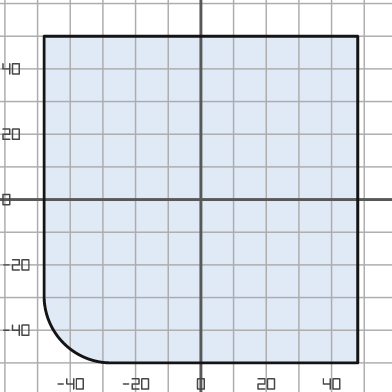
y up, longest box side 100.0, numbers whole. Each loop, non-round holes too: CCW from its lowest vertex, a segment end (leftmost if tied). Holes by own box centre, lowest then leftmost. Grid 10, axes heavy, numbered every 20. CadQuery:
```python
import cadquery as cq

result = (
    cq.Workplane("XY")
    .moveTo(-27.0, -50.0)
    .lineTo(48.0, -50.0)
    .lineTo(48.0, 50.0)
    .lineTo(-48.0, 50.0)
    .lineTo(-48.0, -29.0)
    .threePointArc((-42.0, -44.0), (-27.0, -50.0))
    .close()
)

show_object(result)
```